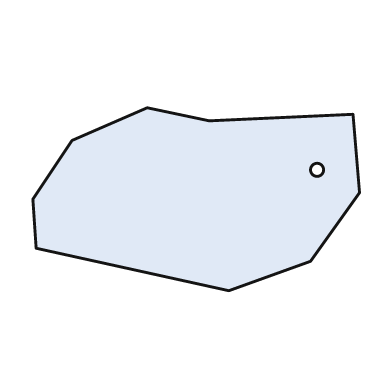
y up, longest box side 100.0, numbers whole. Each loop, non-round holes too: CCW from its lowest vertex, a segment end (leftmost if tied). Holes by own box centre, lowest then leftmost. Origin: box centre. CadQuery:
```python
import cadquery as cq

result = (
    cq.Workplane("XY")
    .moveTo(10.0, -28.0)
    .lineTo(35.0, -19.0)
    .lineTo(50.0, 2.0)
    .lineTo(48.0, 26.0)
    .lineTo(4.0, 24.0)
    .lineTo(-15.0, 28.0)
    .lineTo(-38.0, 18.0)
    .lineTo(-50.0, 0.0)
    .lineTo(-49.0, -15.0)
    .close()
    .moveTo(37.0, 9.0)
    .circle(2.0)
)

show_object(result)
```